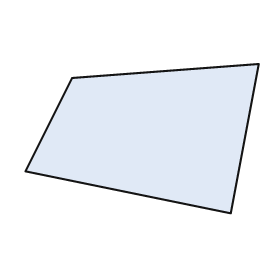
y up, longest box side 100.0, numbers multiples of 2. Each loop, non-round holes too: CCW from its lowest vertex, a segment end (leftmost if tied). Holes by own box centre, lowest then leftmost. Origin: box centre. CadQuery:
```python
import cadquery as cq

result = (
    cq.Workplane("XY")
    .moveTo(38.0, -32.0)
    .lineTo(50.0, 32.0)
    .lineTo(-30.0, 26.0)
    .lineTo(-50.0, -14.0)
    .close()
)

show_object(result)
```